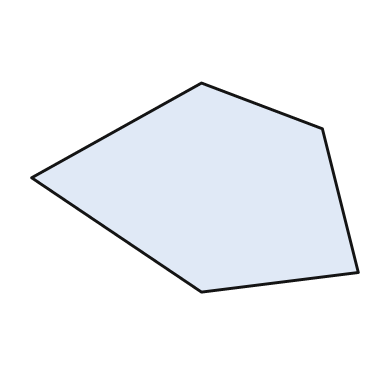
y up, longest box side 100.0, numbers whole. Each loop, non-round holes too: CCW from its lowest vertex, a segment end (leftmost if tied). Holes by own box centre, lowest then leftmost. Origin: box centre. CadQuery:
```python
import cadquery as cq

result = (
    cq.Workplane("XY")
    .moveTo(2.0, -32.0)
    .lineTo(50.0, -26.0)
    .lineTo(39.0, 18.0)
    .lineTo(2.0, 32.0)
    .lineTo(-50.0, 3.0)
    .close()
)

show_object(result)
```